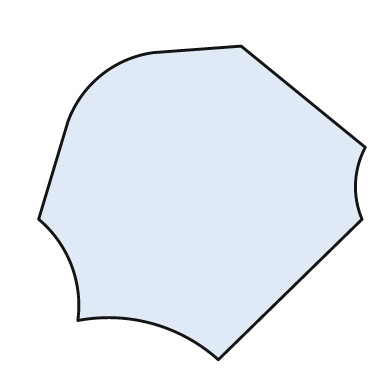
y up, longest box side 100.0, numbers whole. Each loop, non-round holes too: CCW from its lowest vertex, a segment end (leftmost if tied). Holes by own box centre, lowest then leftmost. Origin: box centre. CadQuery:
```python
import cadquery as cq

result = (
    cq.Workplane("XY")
    .moveTo(5.0, -48.0)
    .lineTo(49.0, -5.0)
    .threePointArc((47.0, 6.0), (50.0, 17.0))
    .lineTo(12.0, 48.0)
    .lineTo(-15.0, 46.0)
    .threePointArc((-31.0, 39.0), (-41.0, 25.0))
    .lineTo(-50.0, -5.0)
    .threePointArc((-40.0, -19.0), (-38.0, -36.0))
    .threePointArc((-15.0, -37.0), (5.0, -48.0))
    .close()
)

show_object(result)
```